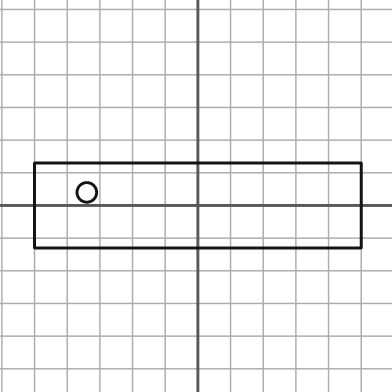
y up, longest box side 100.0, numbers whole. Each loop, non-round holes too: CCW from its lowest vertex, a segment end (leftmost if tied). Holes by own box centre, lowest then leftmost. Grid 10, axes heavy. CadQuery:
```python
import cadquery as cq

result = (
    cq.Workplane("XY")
    .moveTo(-50.0, -13.0)
    .lineTo(50.0, -13.0)
    .lineTo(50.0, 13.0)
    .lineTo(-50.0, 13.0)
    .close()
    .moveTo(-34.0, 4.0)
    .circle(3.0)
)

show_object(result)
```